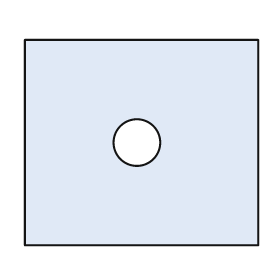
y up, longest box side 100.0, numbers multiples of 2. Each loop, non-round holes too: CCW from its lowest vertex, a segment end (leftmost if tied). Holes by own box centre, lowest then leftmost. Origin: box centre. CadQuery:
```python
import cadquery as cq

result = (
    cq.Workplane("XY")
    .moveTo(-50.0, -44.0)
    .lineTo(50.0, -44.0)
    .lineTo(50.0, 44.0)
    .lineTo(-50.0, 44.0)
    .close()
    .moveTo(-2.0, 0.0)
    .circle(10.0)
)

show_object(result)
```